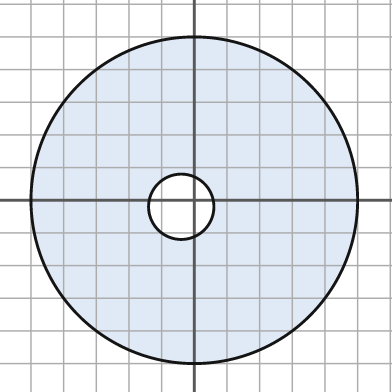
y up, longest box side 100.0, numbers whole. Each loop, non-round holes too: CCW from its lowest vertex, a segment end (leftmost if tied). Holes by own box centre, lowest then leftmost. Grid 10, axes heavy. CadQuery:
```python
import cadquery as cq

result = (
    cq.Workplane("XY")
    .moveTo(0.0, 0.0)
    .circle(50.0)
    .moveTo(-4.0, -2.0)
    .circle(10.0)
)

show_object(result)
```